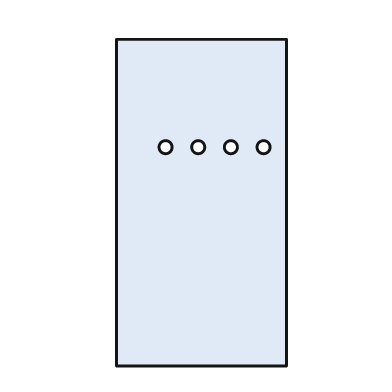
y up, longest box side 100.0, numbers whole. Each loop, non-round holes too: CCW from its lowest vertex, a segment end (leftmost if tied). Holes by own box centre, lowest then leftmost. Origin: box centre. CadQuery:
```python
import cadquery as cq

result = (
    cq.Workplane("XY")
    .moveTo(-26.0, -50.0)
    .lineTo(26.0, -50.0)
    .lineTo(26.0, 50.0)
    .lineTo(-26.0, 50.0)
    .close()
    .moveTo(-11.0, 17.0)
    .circle(2.0)
    .moveTo(-1.0, 17.0)
    .circle(2.0)
    .moveTo(9.0, 17.0)
    .circle(2.0)
    .moveTo(19.0, 17.0)
    .circle(2.0)
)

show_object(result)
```